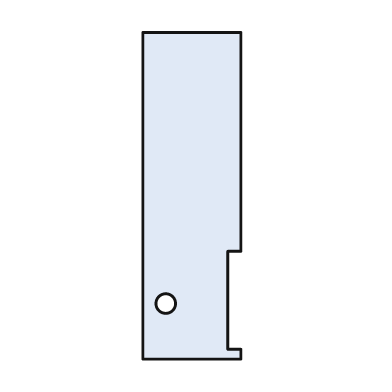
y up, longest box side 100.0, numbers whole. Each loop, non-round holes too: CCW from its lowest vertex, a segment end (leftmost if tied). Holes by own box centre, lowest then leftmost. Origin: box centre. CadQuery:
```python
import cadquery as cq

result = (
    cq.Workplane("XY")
    .moveTo(-15.0, -50.0)
    .lineTo(15.0, -50.0)
    .lineTo(15.0, -47.0)
    .lineTo(11.0, -47.0)
    .lineTo(11.0, -17.0)
    .lineTo(15.0, -17.0)
    .lineTo(15.0, 50.0)
    .lineTo(-15.0, 50.0)
    .close()
    .moveTo(-8.0, -33.0)
    .circle(3.0)
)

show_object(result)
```